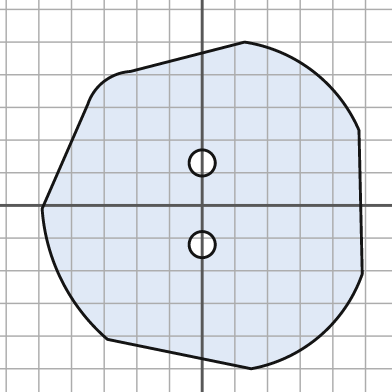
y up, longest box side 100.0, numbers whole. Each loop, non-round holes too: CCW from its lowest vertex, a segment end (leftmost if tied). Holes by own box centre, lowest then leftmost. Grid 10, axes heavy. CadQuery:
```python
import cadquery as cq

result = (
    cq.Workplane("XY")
    .moveTo(15.0, -50.0)
    .threePointArc((36.0, -40.0), (49.0, -21.0))
    .lineTo(48.0, 23.0)
    .threePointArc((34.0, 41.0), (13.0, 50.0))
    .lineTo(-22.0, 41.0)
    .threePointArc((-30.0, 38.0), (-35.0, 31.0))
    .lineTo(-49.0, -1.0)
    .threePointArc((-43.0, -23.0), (-29.0, -41.0))
    .close()
    .moveTo(0.0, -12.0)
    .circle(4.0)
    .moveTo(0.0, 13.0)
    .circle(4.0)
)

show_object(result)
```